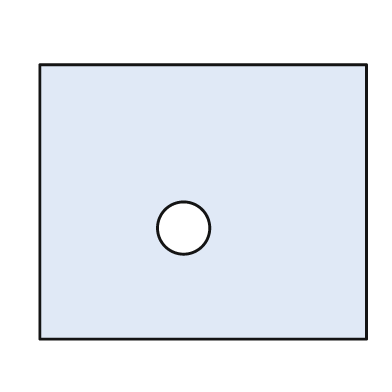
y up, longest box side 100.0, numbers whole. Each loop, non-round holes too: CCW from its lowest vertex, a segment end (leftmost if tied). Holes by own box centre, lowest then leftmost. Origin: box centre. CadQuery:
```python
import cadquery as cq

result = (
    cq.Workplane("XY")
    .moveTo(-50.0, -42.0)
    .lineTo(50.0, -42.0)
    .lineTo(50.0, 42.0)
    .lineTo(-50.0, 42.0)
    .close()
    .moveTo(-6.0, -8.0)
    .circle(8.0)
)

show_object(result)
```